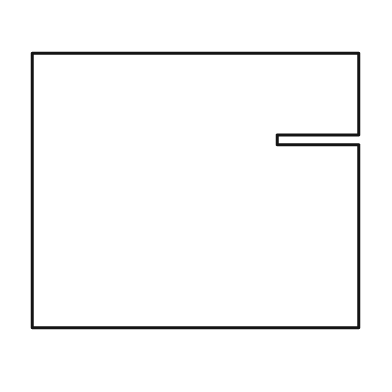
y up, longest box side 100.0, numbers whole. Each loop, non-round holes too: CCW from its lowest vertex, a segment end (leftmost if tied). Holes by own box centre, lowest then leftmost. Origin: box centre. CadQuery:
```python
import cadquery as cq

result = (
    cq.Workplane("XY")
    .moveTo(-50.0, -42.0)
    .lineTo(50.0, -42.0)
    .lineTo(50.0, 14.0)
    .lineTo(25.0, 14.0)
    .lineTo(25.0, 17.0)
    .lineTo(50.0, 17.0)
    .lineTo(50.0, 42.0)
    .lineTo(-50.0, 42.0)
    .close()
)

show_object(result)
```